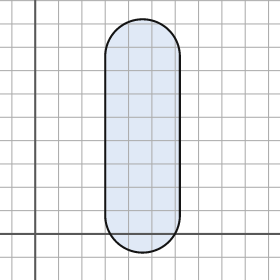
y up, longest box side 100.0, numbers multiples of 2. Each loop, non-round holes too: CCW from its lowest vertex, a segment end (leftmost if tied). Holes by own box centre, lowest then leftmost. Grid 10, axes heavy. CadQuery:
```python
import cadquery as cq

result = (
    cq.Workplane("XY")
    .moveTo(30.0, 8.0)
    .threePointArc((46.0, -8.0), (62.0, 8.0))
    .lineTo(62.0, 76.0)
    .threePointArc((46.0, 92.0), (30.0, 76.0))
    .close()
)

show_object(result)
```